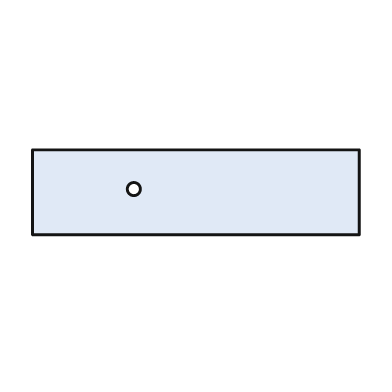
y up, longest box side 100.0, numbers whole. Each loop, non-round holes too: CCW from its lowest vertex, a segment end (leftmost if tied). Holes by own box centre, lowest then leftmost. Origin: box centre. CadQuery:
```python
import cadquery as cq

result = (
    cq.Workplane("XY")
    .moveTo(-50.0, -13.0)
    .lineTo(50.0, -13.0)
    .lineTo(50.0, 13.0)
    .lineTo(-50.0, 13.0)
    .close()
    .moveTo(-19.0, 1.0)
    .circle(2.0)
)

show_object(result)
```